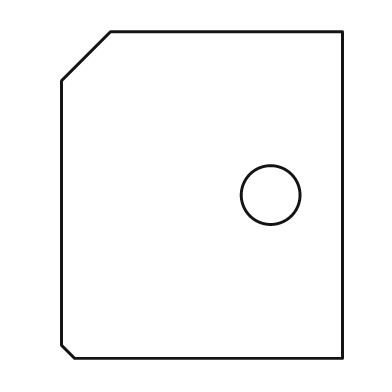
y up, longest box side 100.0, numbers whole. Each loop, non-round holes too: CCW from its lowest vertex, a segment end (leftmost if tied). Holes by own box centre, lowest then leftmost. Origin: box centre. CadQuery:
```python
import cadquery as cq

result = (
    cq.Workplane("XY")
    .moveTo(-39.0, -50.0)
    .lineTo(43.0, -50.0)
    .lineTo(43.0, 50.0)
    .lineTo(-28.0, 50.0)
    .lineTo(-43.0, 35.0)
    .lineTo(-43.0, -46.0)
    .close()
    .moveTo(21.0, 0.0)
    .circle(9.0)
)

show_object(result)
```